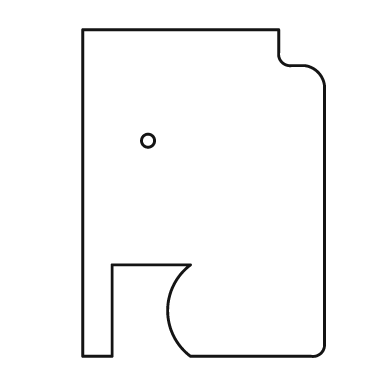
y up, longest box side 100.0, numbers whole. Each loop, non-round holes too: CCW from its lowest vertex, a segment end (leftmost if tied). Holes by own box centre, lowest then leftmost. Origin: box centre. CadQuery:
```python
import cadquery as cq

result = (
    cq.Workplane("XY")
    .moveTo(-37.0, -50.0)
    .lineTo(-28.0, -50.0)
    .lineTo(-28.0, -22.0)
    .lineTo(-4.0, -22.0)
    .threePointArc((-11.0, -36.0), (-4.0, -50.0))
    .lineTo(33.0, -50.0)
    .threePointArc((36.0, -49.0), (37.0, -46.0))
    .lineTo(37.0, 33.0)
    .threePointArc((35.0, 37.0), (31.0, 39.0))
    .lineTo(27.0, 39.0)
    .threePointArc((24.0, 40.0), (23.0, 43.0))
    .lineTo(23.0, 50.0)
    .lineTo(-37.0, 50.0)
    .close()
    .moveTo(-17.0, 16.0)
    .circle(2.0)
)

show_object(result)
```